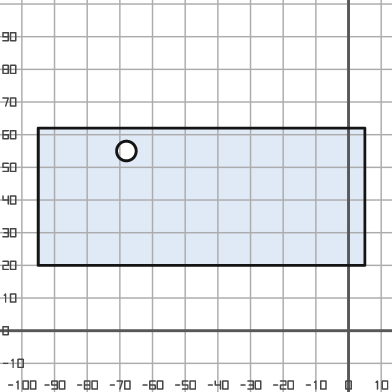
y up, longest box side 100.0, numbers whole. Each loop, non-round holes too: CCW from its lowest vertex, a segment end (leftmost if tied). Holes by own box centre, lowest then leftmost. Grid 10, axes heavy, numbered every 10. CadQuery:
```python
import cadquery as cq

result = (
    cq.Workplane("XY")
    .moveTo(-95.0, 20.0)
    .lineTo(5.0, 20.0)
    .lineTo(5.0, 62.0)
    .lineTo(-95.0, 62.0)
    .close()
    .moveTo(-68.0, 55.0)
    .circle(3.0)
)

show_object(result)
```